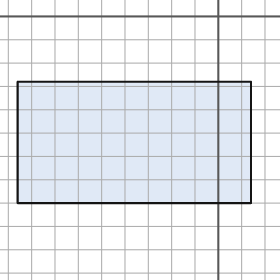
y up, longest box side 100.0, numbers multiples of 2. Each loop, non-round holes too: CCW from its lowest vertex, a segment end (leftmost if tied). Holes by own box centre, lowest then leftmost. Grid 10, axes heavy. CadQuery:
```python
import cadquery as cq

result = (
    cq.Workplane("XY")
    .moveTo(-86.0, -80.0)
    .lineTo(14.0, -80.0)
    .lineTo(14.0, -28.0)
    .lineTo(-86.0, -28.0)
    .close()
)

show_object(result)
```